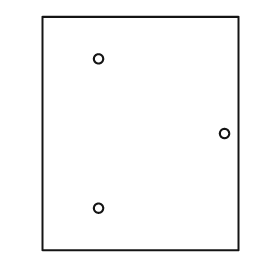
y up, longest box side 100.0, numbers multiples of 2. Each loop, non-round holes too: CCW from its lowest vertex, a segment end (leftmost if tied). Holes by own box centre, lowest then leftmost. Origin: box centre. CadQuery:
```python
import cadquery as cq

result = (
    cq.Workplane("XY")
    .moveTo(-42.0, -50.0)
    .lineTo(42.0, -50.0)
    .lineTo(42.0, 50.0)
    .lineTo(-42.0, 50.0)
    .close()
    .moveTo(-18.0, -32.0)
    .circle(2.0)
    .moveTo(36.0, 0.0)
    .circle(2.0)
    .moveTo(-18.0, 32.0)
    .circle(2.0)
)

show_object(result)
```